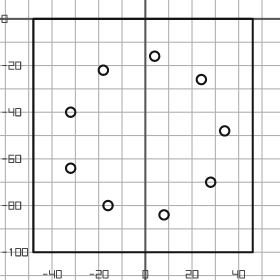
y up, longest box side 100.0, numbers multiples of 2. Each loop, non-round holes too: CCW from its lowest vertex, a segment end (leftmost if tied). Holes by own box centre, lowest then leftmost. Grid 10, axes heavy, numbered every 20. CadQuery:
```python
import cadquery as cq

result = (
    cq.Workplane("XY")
    .moveTo(-48.0, -100.0)
    .lineTo(46.0, -100.0)
    .lineTo(46.0, 0.0)
    .lineTo(-48.0, 0.0)
    .close()
    .moveTo(8.0, -84.0)
    .circle(2.0)
    .moveTo(-16.0, -80.0)
    .circle(2.0)
    .moveTo(28.0, -70.0)
    .circle(2.0)
    .moveTo(-32.0, -64.0)
    .circle(2.0)
    .moveTo(34.0, -48.0)
    .circle(2.0)
    .moveTo(-32.0, -40.0)
    .circle(2.0)
    .moveTo(24.0, -26.0)
    .circle(2.0)
    .moveTo(-18.0, -22.0)
    .circle(2.0)
    .moveTo(4.0, -16.0)
    .circle(2.0)
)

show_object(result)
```